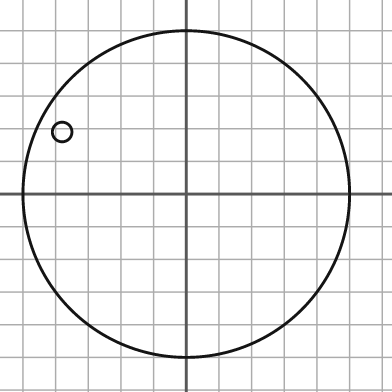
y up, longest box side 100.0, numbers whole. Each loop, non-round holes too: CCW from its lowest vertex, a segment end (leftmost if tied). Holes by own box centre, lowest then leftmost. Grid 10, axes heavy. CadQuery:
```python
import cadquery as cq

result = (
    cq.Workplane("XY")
    .moveTo(0.0, 0.0)
    .circle(50.0)
    .moveTo(-38.0, 19.0)
    .circle(3.0)
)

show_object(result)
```